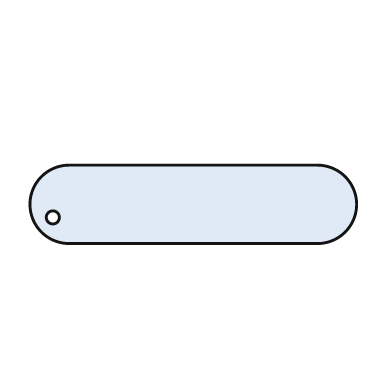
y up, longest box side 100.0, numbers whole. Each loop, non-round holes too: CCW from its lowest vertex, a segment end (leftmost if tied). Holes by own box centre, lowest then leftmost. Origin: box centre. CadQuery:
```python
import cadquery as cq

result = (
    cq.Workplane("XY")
    .moveTo(-38.0, -12.0)
    .lineTo(38.0, -12.0)
    .threePointArc((50.0, 0.0), (38.0, 12.0))
    .lineTo(-38.0, 12.0)
    .threePointArc((-50.0, 0.0), (-38.0, -12.0))
    .close()
    .moveTo(-43.0, -4.0)
    .circle(2.0)
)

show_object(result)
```